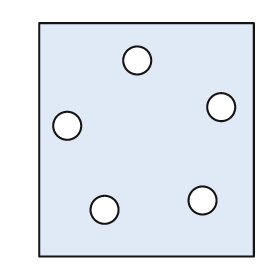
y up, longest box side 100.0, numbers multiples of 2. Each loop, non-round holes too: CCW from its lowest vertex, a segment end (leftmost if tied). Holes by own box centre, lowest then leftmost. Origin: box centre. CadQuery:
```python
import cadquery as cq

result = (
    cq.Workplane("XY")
    .moveTo(-46.0, -50.0)
    .lineTo(46.0, -50.0)
    .lineTo(46.0, 50.0)
    .lineTo(-46.0, 50.0)
    .close()
    .moveTo(-18.0, -30.0)
    .circle(6.0)
    .moveTo(24.0, -26.0)
    .circle(6.0)
    .moveTo(-34.0, 6.0)
    .circle(6.0)
    .moveTo(32.0, 14.0)
    .circle(6.0)
    .moveTo(-4.0, 34.0)
    .circle(6.0)
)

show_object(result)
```